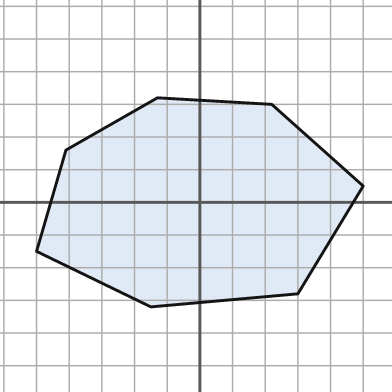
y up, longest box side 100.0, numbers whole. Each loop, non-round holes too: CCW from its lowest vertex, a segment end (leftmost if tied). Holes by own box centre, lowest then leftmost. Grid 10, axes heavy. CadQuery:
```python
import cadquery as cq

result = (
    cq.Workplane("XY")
    .moveTo(-15.0, -32.0)
    .lineTo(30.0, -28.0)
    .lineTo(50.0, 5.0)
    .lineTo(22.0, 30.0)
    .lineTo(-13.0, 32.0)
    .lineTo(-41.0, 16.0)
    .lineTo(-50.0, -15.0)
    .close()
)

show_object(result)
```